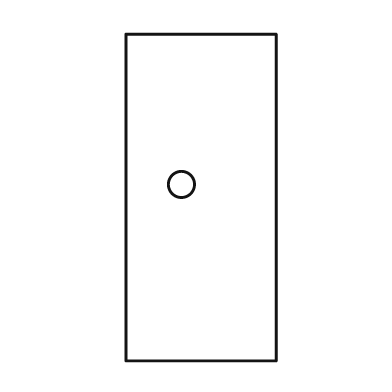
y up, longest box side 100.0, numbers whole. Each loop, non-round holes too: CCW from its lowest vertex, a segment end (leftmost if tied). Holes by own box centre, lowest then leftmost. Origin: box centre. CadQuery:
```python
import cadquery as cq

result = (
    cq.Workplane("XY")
    .moveTo(-23.0, -50.0)
    .lineTo(23.0, -50.0)
    .lineTo(23.0, 50.0)
    .lineTo(-23.0, 50.0)
    .close()
    .moveTo(-6.0, 4.0)
    .circle(4.0)
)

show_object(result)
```